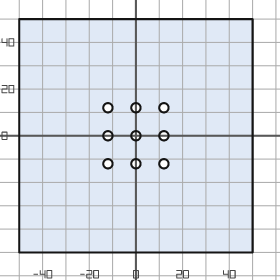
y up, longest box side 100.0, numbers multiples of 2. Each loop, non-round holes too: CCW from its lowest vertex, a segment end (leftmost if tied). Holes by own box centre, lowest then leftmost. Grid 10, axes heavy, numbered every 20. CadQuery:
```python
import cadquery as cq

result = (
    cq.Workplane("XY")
    .moveTo(-50.0, -50.0)
    .lineTo(50.0, -50.0)
    .lineTo(50.0, 50.0)
    .lineTo(-50.0, 50.0)
    .close()
    .moveTo(-12.0, -12.0)
    .circle(2.0)
    .moveTo(0.0, -12.0)
    .circle(2.0)
    .moveTo(12.0, -12.0)
    .circle(2.0)
    .moveTo(-12.0, 0.0)
    .circle(2.0)
    .moveTo(0.0, 0.0)
    .circle(2.0)
    .moveTo(12.0, 0.0)
    .circle(2.0)
    .moveTo(-12.0, 12.0)
    .circle(2.0)
    .moveTo(0.0, 12.0)
    .circle(2.0)
    .moveTo(12.0, 12.0)
    .circle(2.0)
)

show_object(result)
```